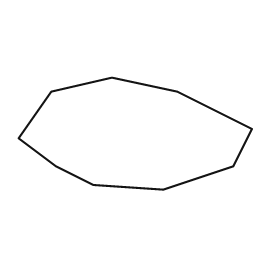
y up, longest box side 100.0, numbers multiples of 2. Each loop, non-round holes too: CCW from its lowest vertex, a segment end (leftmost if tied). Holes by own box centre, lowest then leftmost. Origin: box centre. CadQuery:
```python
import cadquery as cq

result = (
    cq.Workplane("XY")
    .moveTo(12.0, -24.0)
    .lineTo(42.0, -14.0)
    .lineTo(50.0, 2.0)
    .lineTo(18.0, 18.0)
    .lineTo(-10.0, 24.0)
    .lineTo(-36.0, 18.0)
    .lineTo(-50.0, -2.0)
    .lineTo(-34.0, -14.0)
    .lineTo(-18.0, -22.0)
    .close()
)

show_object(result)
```